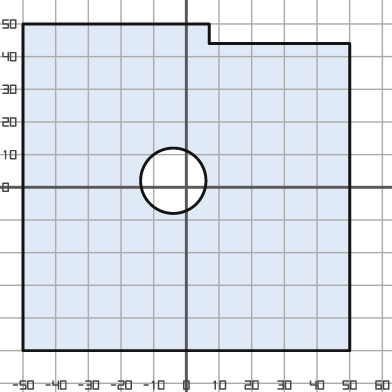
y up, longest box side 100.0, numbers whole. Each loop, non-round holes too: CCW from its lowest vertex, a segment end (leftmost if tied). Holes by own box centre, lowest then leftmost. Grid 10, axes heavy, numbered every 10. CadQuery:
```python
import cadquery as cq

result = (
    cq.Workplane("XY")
    .moveTo(-50.0, -50.0)
    .lineTo(50.0, -50.0)
    .lineTo(50.0, 44.0)
    .lineTo(7.0, 44.0)
    .lineTo(7.0, 50.0)
    .lineTo(-50.0, 50.0)
    .close()
    .moveTo(-4.0, 2.0)
    .circle(10.0)
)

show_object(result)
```